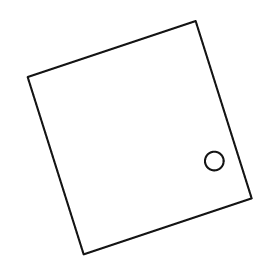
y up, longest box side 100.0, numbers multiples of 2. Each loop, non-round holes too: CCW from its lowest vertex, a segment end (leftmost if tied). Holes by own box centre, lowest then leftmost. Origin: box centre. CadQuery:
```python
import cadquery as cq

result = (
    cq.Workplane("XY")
    .moveTo(-24.0, -50.0)
    .lineTo(48.0, -26.0)
    .lineTo(24.0, 50.0)
    .lineTo(-48.0, 26.0)
    .close()
    .moveTo(32.0, -10.0)
    .circle(4.0)
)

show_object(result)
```